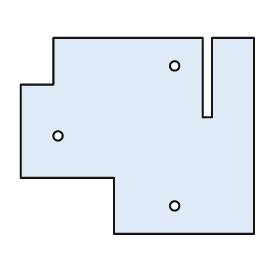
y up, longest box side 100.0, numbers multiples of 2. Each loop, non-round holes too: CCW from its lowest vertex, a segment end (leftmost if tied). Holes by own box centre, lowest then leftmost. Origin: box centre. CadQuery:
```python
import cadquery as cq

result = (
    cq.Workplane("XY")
    .moveTo(-10.0, -42.0)
    .lineTo(50.0, -42.0)
    .lineTo(50.0, 42.0)
    .lineTo(32.0, 42.0)
    .lineTo(32.0, 8.0)
    .lineTo(28.0, 8.0)
    .lineTo(28.0, 42.0)
    .lineTo(-36.0, 42.0)
    .lineTo(-36.0, 22.0)
    .lineTo(-50.0, 22.0)
    .lineTo(-50.0, -18.0)
    .lineTo(-10.0, -18.0)
    .close()
    .moveTo(16.0, -30.0)
    .circle(2.0)
    .moveTo(-34.0, 0.0)
    .circle(2.0)
    .moveTo(16.0, 30.0)
    .circle(2.0)
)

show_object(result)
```